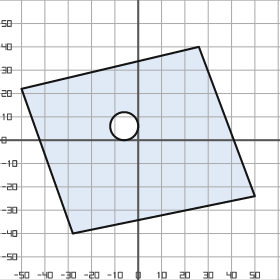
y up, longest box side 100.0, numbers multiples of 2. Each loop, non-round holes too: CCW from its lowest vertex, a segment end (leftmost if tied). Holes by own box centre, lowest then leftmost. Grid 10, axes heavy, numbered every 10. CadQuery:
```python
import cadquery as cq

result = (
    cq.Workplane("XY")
    .moveTo(-28.0, -40.0)
    .lineTo(50.0, -24.0)
    .lineTo(26.0, 40.0)
    .lineTo(-50.0, 22.0)
    .close()
    .moveTo(-6.0, 6.0)
    .circle(6.0)
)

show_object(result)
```